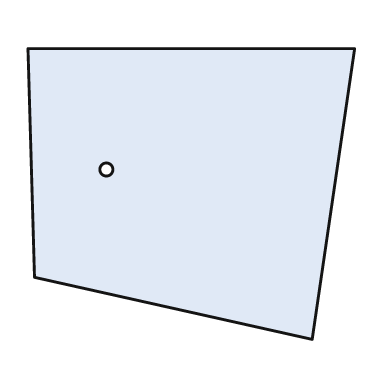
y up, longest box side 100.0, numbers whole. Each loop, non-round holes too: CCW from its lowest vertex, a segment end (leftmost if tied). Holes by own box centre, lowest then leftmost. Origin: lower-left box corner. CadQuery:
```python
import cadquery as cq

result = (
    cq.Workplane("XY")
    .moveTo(87.0, 0.0)
    .lineTo(100.0, 89.0)
    .lineTo(0.0, 89.0)
    .lineTo(2.0, 19.0)
    .close()
    .moveTo(24.0, 52.0)
    .circle(2.0)
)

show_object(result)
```